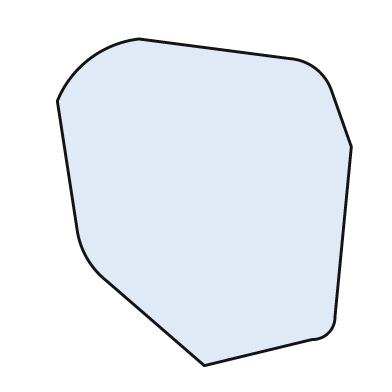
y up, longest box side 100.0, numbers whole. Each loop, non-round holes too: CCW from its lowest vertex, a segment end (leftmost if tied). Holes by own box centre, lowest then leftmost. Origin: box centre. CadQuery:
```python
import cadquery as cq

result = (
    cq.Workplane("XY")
    .moveTo(0.0, -50.0)
    .lineTo(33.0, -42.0)
    .threePointArc((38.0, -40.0), (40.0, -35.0))
    .lineTo(45.0, 17.0)
    .lineTo(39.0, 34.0)
    .threePointArc((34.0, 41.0), (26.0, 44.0))
    .lineTo(-20.0, 50.0)
    .threePointArc((-35.0, 44.0), (-45.0, 31.0))
    .lineTo(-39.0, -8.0)
    .threePointArc((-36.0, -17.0), (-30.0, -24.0))
    .close()
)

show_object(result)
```